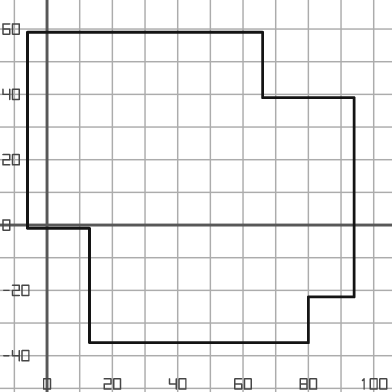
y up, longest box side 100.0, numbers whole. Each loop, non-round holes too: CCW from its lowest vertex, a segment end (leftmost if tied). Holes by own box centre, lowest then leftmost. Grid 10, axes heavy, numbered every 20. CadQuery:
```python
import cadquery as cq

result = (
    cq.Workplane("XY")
    .moveTo(13.0, -36.0)
    .lineTo(80.0, -36.0)
    .lineTo(80.0, -22.0)
    .lineTo(94.0, -22.0)
    .lineTo(94.0, 39.0)
    .lineTo(66.0, 39.0)
    .lineTo(66.0, 59.0)
    .lineTo(-6.0, 59.0)
    .lineTo(-6.0, -1.0)
    .lineTo(13.0, -1.0)
    .close()
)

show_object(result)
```